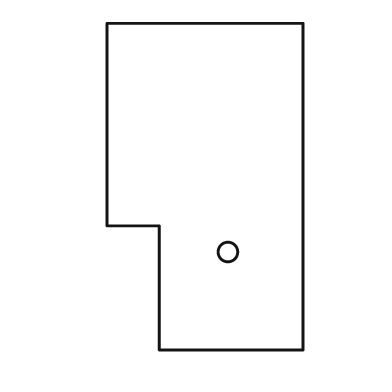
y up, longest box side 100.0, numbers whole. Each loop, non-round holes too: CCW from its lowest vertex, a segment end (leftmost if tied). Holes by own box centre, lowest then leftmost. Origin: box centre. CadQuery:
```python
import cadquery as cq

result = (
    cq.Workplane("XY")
    .moveTo(-14.0, -50.0)
    .lineTo(30.0, -50.0)
    .lineTo(30.0, 50.0)
    .lineTo(-30.0, 50.0)
    .lineTo(-30.0, -12.0)
    .lineTo(-14.0, -12.0)
    .close()
    .moveTo(7.0, -20.0)
    .circle(3.0)
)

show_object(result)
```